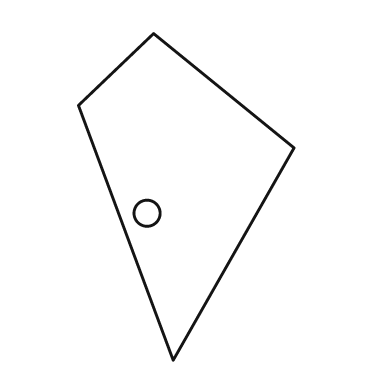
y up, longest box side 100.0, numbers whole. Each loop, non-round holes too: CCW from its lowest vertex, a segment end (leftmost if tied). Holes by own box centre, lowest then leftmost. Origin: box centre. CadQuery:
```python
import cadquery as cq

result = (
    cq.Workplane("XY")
    .moveTo(-4.0, -50.0)
    .lineTo(33.0, 15.0)
    .lineTo(-10.0, 50.0)
    .lineTo(-33.0, 28.0)
    .close()
    .moveTo(-12.0, -5.0)
    .circle(4.0)
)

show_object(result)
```